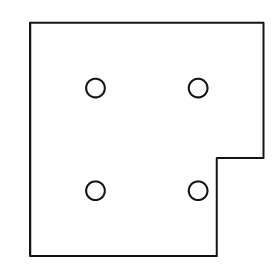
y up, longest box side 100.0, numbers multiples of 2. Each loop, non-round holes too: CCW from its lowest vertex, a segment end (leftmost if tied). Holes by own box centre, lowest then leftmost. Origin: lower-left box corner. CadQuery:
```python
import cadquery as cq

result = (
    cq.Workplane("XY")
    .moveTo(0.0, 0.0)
    .lineTo(80.0, 0.0)
    .lineTo(80.0, 42.0)
    .lineTo(100.0, 42.0)
    .lineTo(100.0, 100.0)
    .lineTo(0.0, 100.0)
    .close()
    .moveTo(28.0, 28.0)
    .circle(4.0)
    .moveTo(72.0, 28.0)
    .circle(4.0)
    .moveTo(28.0, 72.0)
    .circle(4.0)
    .moveTo(72.0, 72.0)
    .circle(4.0)
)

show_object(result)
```